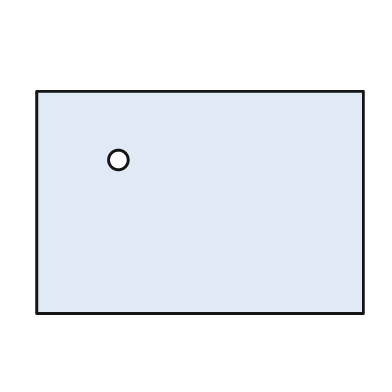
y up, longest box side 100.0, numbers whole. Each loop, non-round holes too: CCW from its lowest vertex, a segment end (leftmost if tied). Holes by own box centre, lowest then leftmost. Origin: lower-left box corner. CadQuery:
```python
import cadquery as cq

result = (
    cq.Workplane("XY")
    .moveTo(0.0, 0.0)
    .lineTo(100.0, 0.0)
    .lineTo(100.0, 68.0)
    .lineTo(0.0, 68.0)
    .close()
    .moveTo(25.0, 47.0)
    .circle(3.0)
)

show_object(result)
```